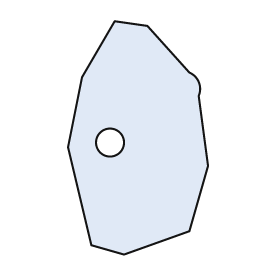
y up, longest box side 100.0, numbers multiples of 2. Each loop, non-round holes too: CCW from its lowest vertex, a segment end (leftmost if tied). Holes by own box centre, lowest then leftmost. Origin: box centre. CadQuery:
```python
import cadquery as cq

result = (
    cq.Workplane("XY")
    .moveTo(-6.0, -50.0)
    .lineTo(22.0, -40.0)
    .lineTo(30.0, -12.0)
    .lineTo(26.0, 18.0)
    .threePointArc((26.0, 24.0), (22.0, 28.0))
    .lineTo(4.0, 48.0)
    .lineTo(-10.0, 50.0)
    .lineTo(-24.0, 26.0)
    .lineTo(-30.0, -4.0)
    .lineTo(-20.0, -46.0)
    .close()
    .moveTo(-12.0, -2.0)
    .circle(6.0)
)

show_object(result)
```